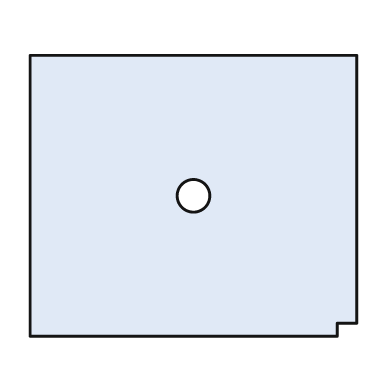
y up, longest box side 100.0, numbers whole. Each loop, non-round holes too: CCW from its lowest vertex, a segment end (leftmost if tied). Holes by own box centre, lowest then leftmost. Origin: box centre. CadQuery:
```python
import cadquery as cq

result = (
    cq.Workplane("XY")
    .moveTo(-50.0, -43.0)
    .lineTo(44.0, -43.0)
    .lineTo(44.0, -39.0)
    .lineTo(50.0, -39.0)
    .lineTo(50.0, 43.0)
    .lineTo(-50.0, 43.0)
    .close()
    .moveTo(0.0, 0.0)
    .circle(5.0)
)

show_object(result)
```